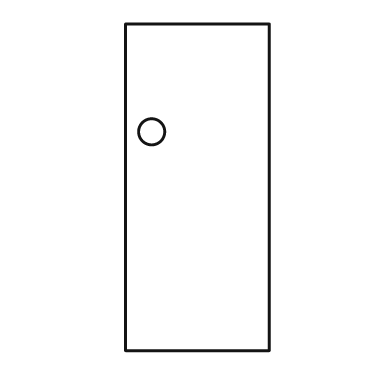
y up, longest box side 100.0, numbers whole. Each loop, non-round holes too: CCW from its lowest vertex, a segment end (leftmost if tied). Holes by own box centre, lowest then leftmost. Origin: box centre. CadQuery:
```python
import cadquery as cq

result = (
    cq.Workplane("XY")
    .moveTo(-22.0, -50.0)
    .lineTo(22.0, -50.0)
    .lineTo(22.0, 50.0)
    .lineTo(-22.0, 50.0)
    .close()
    .moveTo(-14.0, 17.0)
    .circle(4.0)
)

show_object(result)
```